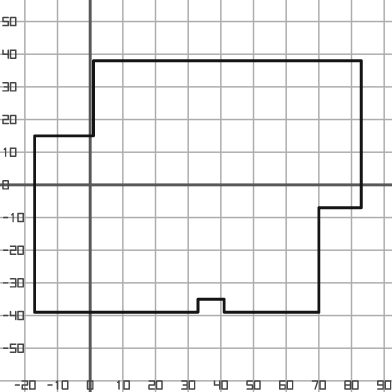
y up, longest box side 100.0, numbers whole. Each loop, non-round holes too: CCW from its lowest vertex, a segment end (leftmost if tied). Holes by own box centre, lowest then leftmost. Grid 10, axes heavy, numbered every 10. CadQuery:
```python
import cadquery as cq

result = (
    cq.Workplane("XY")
    .moveTo(-17.0, -39.0)
    .lineTo(33.0, -39.0)
    .lineTo(33.0, -35.0)
    .lineTo(41.0, -35.0)
    .lineTo(41.0, -39.0)
    .lineTo(70.0, -39.0)
    .lineTo(70.0, -7.0)
    .lineTo(83.0, -7.0)
    .lineTo(83.0, 38.0)
    .lineTo(1.0, 38.0)
    .lineTo(1.0, 15.0)
    .lineTo(-17.0, 15.0)
    .close()
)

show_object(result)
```